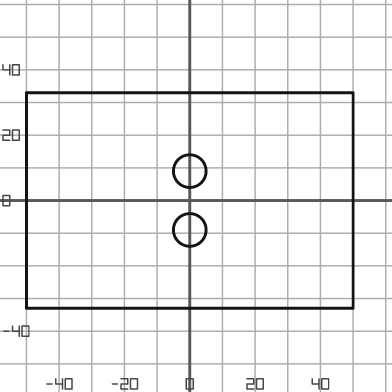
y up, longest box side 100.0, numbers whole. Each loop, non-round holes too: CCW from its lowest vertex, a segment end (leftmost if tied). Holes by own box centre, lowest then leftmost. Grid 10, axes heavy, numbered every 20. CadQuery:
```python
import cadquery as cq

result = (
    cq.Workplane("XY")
    .moveTo(-50.0, -33.0)
    .lineTo(50.0, -33.0)
    .lineTo(50.0, 33.0)
    .lineTo(-50.0, 33.0)
    .close()
    .moveTo(0.0, -9.0)
    .circle(5.0)
    .moveTo(0.0, 9.0)
    .circle(5.0)
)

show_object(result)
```